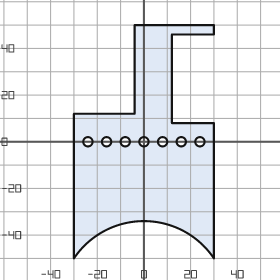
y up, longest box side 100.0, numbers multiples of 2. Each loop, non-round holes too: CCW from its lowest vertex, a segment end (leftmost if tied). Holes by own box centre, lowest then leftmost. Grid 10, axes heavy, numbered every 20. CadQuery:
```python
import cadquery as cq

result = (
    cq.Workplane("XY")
    .moveTo(-30.0, -50.0)
    .threePointArc((0.0, -34.0), (30.0, -50.0))
    .lineTo(30.0, 8.0)
    .lineTo(12.0, 8.0)
    .lineTo(12.0, 46.0)
    .lineTo(30.0, 46.0)
    .lineTo(30.0, 50.0)
    .lineTo(-4.0, 50.0)
    .lineTo(-4.0, 12.0)
    .lineTo(-30.0, 12.0)
    .close()
    .moveTo(-24.0, 0.0)
    .circle(2.0)
    .moveTo(-16.0, 0.0)
    .circle(2.0)
    .moveTo(-8.0, 0.0)
    .circle(2.0)
    .moveTo(0.0, 0.0)
    .circle(2.0)
    .moveTo(8.0, 0.0)
    .circle(2.0)
    .moveTo(16.0, 0.0)
    .circle(2.0)
    .moveTo(24.0, 0.0)
    .circle(2.0)
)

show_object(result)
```